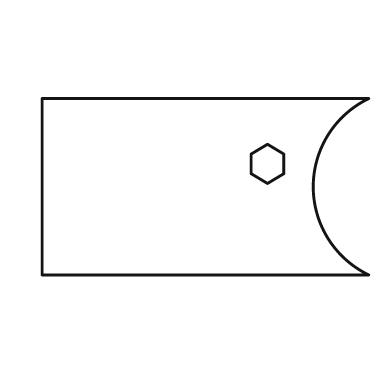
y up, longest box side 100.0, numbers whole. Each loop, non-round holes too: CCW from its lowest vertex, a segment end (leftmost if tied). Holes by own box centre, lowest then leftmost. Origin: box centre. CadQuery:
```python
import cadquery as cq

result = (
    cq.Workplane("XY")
    .moveTo(-50.0, -27.0)
    .lineTo(50.0, -27.0)
    .threePointArc((33.0, 0.0), (50.0, 27.0))
    .lineTo(-50.0, 27.0)
    .close()
    .moveTo(19.0, 1.0)
    .lineTo(24.0, 4.0)
    .lineTo(24.0, 10.0)
    .lineTo(19.0, 13.0)
    .lineTo(14.0, 10.0)
    .lineTo(14.0, 4.0)
    .close()
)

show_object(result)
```